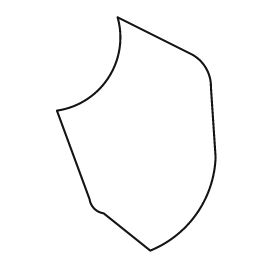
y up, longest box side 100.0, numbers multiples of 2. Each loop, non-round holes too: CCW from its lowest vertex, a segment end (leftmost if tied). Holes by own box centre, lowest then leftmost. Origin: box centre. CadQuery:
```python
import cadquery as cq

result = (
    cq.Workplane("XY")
    .moveTo(6.0, -50.0)
    .threePointArc((26.0, -34.0), (34.0, -10.0))
    .lineTo(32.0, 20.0)
    .threePointArc((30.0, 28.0), (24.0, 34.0))
    .lineTo(-8.0, 50.0)
    .threePointArc((-12.0, 24.0), (-34.0, 10.0))
    .lineTo(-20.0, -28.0)
    .threePointArc((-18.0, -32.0), (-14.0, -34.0))
    .close()
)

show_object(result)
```